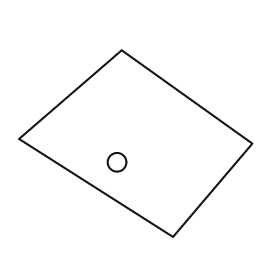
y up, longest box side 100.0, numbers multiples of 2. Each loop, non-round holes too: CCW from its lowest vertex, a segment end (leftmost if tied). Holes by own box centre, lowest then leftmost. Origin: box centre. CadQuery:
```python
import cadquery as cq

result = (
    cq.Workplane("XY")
    .moveTo(16.0, -40.0)
    .lineTo(50.0, 0.0)
    .lineTo(-6.0, 40.0)
    .lineTo(-50.0, 2.0)
    .close()
    .moveTo(-8.0, -8.0)
    .circle(4.0)
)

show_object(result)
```